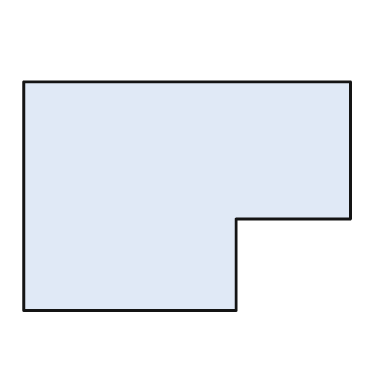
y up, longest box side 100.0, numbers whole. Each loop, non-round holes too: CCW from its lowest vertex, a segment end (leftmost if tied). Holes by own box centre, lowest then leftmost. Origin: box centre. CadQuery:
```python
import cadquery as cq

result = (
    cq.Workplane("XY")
    .moveTo(-50.0, -35.0)
    .lineTo(15.0, -35.0)
    .lineTo(15.0, -7.0)
    .lineTo(50.0, -7.0)
    .lineTo(50.0, 35.0)
    .lineTo(-50.0, 35.0)
    .close()
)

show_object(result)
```